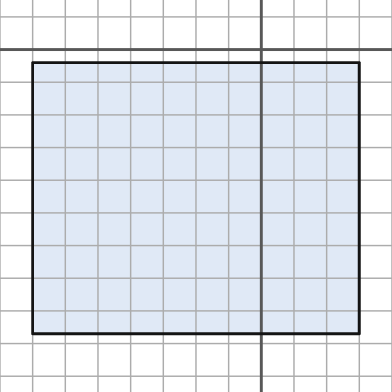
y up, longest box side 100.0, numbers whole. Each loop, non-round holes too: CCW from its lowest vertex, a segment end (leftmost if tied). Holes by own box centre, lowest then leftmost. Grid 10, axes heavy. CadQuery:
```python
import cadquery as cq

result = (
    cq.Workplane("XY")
    .moveTo(-70.0, -87.0)
    .lineTo(30.0, -87.0)
    .lineTo(30.0, -4.0)
    .lineTo(-70.0, -4.0)
    .close()
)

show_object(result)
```